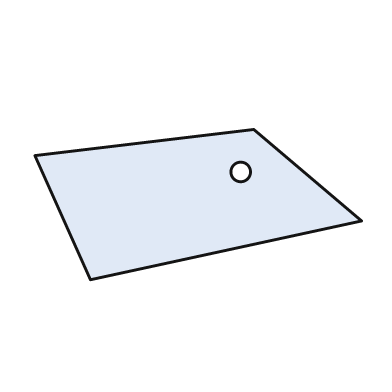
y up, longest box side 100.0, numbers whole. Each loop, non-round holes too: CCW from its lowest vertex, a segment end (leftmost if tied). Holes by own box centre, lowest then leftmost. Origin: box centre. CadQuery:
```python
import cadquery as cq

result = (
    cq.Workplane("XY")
    .moveTo(-33.0, -23.0)
    .lineTo(50.0, -5.0)
    .lineTo(17.0, 23.0)
    .lineTo(-50.0, 15.0)
    .close()
    .moveTo(13.0, 10.0)
    .circle(3.0)
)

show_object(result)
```